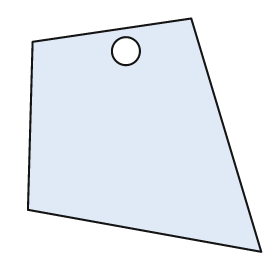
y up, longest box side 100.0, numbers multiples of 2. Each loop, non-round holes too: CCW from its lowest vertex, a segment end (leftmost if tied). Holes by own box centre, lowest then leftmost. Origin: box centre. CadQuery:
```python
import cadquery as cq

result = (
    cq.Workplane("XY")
    .moveTo(50.0, -50.0)
    .lineTo(20.0, 50.0)
    .lineTo(-48.0, 40.0)
    .lineTo(-50.0, -32.0)
    .close()
    .moveTo(-8.0, 36.0)
    .circle(6.0)
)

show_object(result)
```